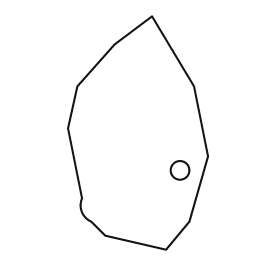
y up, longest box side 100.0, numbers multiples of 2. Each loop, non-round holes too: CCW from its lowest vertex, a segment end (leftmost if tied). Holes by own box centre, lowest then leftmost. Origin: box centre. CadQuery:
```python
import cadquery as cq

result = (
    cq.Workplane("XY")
    .moveTo(12.0, -50.0)
    .lineTo(22.0, -38.0)
    .lineTo(30.0, -10.0)
    .lineTo(24.0, 20.0)
    .lineTo(6.0, 50.0)
    .lineTo(-10.0, 38.0)
    .lineTo(-26.0, 20.0)
    .lineTo(-30.0, 2.0)
    .lineTo(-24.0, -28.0)
    .threePointArc((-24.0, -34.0), (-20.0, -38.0))
    .lineTo(-14.0, -44.0)
    .close()
    .moveTo(18.0, -16.0)
    .circle(4.0)
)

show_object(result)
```